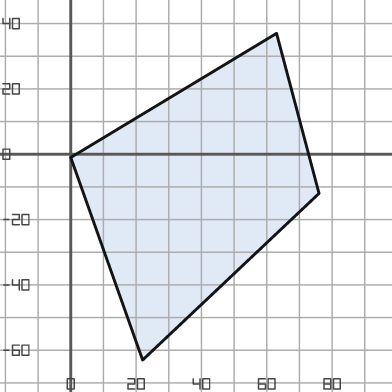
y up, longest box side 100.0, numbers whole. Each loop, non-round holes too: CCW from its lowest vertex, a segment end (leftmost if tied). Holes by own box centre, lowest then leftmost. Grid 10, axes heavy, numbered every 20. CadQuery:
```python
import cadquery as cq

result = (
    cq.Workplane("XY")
    .moveTo(22.0, -63.0)
    .lineTo(76.0, -12.0)
    .lineTo(63.0, 37.0)
    .lineTo(0.0, -1.0)
    .close()
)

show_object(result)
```